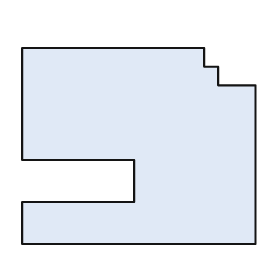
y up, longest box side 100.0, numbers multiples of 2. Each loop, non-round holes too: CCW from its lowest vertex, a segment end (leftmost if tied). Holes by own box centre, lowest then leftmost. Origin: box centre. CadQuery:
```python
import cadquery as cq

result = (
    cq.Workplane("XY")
    .moveTo(-50.0, -42.0)
    .lineTo(50.0, -42.0)
    .lineTo(50.0, 26.0)
    .lineTo(34.0, 26.0)
    .lineTo(34.0, 34.0)
    .lineTo(28.0, 34.0)
    .lineTo(28.0, 42.0)
    .lineTo(-50.0, 42.0)
    .lineTo(-50.0, -6.0)
    .lineTo(-2.0, -6.0)
    .lineTo(-2.0, -24.0)
    .lineTo(-50.0, -24.0)
    .close()
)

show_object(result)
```